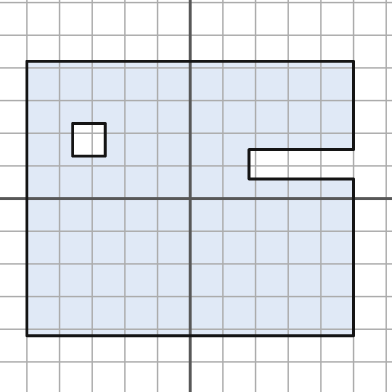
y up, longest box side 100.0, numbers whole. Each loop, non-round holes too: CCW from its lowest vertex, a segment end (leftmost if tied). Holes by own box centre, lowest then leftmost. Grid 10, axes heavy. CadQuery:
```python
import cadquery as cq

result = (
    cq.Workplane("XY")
    .moveTo(-50.0, -42.0)
    .lineTo(50.0, -42.0)
    .lineTo(50.0, 6.0)
    .lineTo(18.0, 6.0)
    .lineTo(18.0, 15.0)
    .lineTo(50.0, 15.0)
    .lineTo(50.0, 42.0)
    .lineTo(-50.0, 42.0)
    .close()
    .moveTo(-36.0, 13.0)
    .lineTo(-26.0, 13.0)
    .lineTo(-26.0, 23.0)
    .lineTo(-36.0, 23.0)
    .close()
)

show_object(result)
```